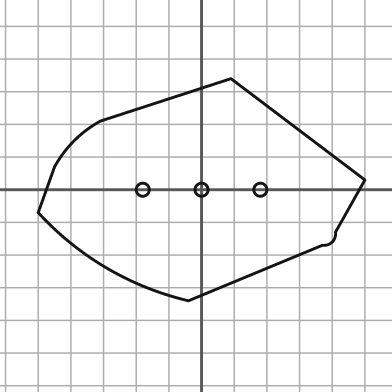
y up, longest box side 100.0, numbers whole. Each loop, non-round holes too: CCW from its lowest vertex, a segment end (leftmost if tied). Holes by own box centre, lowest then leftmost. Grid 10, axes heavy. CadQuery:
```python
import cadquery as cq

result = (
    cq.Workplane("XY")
    .moveTo(-4.0, -34.0)
    .lineTo(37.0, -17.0)
    .threePointArc((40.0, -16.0), (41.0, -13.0))
    .lineTo(50.0, 3.0)
    .lineTo(9.0, 34.0)
    .lineTo(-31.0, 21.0)
    .threePointArc((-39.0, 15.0), (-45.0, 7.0))
    .lineTo(-50.0, -7.0)
    .threePointArc((-29.0, -24.0), (-4.0, -34.0))
    .close()
    .moveTo(-18.0, 0.0)
    .circle(2.0)
    .moveTo(0.0, 0.0)
    .circle(2.0)
    .moveTo(18.0, 0.0)
    .circle(2.0)
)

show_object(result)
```